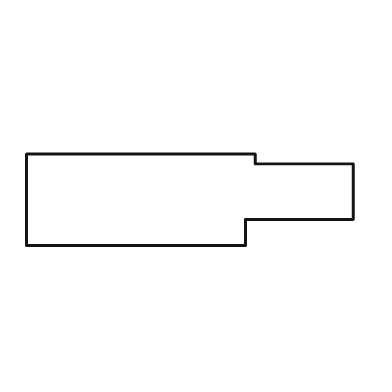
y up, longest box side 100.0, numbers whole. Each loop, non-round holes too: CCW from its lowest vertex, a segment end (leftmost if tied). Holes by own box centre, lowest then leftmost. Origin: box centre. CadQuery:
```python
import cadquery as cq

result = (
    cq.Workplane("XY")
    .moveTo(-50.0, -14.0)
    .lineTo(17.0, -14.0)
    .lineTo(17.0, -6.0)
    .lineTo(50.0, -6.0)
    .lineTo(50.0, 11.0)
    .lineTo(20.0, 11.0)
    .lineTo(20.0, 14.0)
    .lineTo(-50.0, 14.0)
    .close()
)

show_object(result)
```